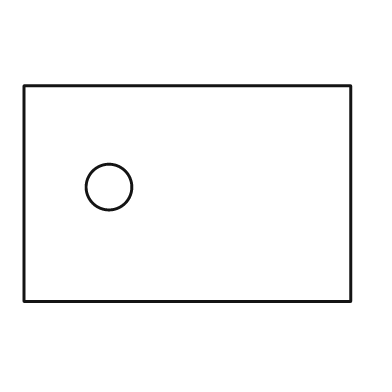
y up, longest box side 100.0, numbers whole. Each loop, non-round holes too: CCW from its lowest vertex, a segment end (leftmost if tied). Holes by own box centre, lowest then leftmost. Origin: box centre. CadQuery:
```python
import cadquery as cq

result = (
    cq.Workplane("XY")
    .moveTo(-50.0, -33.0)
    .lineTo(50.0, -33.0)
    .lineTo(50.0, 33.0)
    .lineTo(-50.0, 33.0)
    .close()
    .moveTo(-24.0, 2.0)
    .circle(7.0)
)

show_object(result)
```